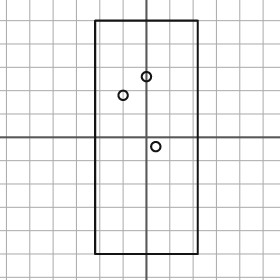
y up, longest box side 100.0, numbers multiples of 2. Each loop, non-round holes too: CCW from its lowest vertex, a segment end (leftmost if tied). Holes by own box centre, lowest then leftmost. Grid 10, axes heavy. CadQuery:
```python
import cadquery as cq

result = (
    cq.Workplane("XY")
    .moveTo(-22.0, -50.0)
    .lineTo(22.0, -50.0)
    .lineTo(22.0, 50.0)
    .lineTo(-22.0, 50.0)
    .close()
    .moveTo(4.0, -4.0)
    .circle(2.0)
    .moveTo(-10.0, 18.0)
    .circle(2.0)
    .moveTo(0.0, 26.0)
    .circle(2.0)
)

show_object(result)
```